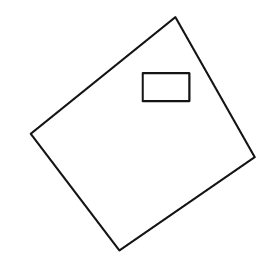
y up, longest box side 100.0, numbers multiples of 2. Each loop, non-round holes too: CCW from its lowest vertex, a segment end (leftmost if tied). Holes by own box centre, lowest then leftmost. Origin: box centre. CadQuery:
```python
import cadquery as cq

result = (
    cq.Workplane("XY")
    .moveTo(-10.0, -50.0)
    .lineTo(48.0, -10.0)
    .lineTo(14.0, 50.0)
    .lineTo(-48.0, 0.0)
    .close()
    .moveTo(0.0, 14.0)
    .lineTo(20.0, 14.0)
    .lineTo(20.0, 26.0)
    .lineTo(0.0, 26.0)
    .close()
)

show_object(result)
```